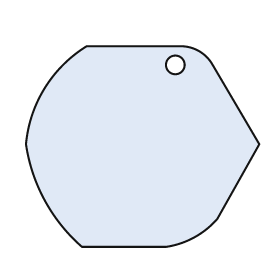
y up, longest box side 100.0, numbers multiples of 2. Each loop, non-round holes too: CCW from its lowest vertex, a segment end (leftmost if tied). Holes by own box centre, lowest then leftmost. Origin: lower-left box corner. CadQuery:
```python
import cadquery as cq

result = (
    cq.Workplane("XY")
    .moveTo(24.0, 0.0)
    .lineTo(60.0, 0.0)
    .threePointArc((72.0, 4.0), (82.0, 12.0))
    .lineTo(100.0, 44.0)
    .lineTo(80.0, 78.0)
    .threePointArc((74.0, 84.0), (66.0, 86.0))
    .lineTo(26.0, 86.0)
    .threePointArc((8.0, 68.0), (0.0, 44.0))
    .threePointArc((8.0, 20.0), (24.0, 0.0))
    .close()
    .moveTo(64.0, 78.0)
    .circle(4.0)
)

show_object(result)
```